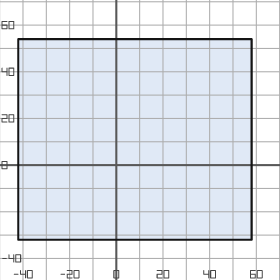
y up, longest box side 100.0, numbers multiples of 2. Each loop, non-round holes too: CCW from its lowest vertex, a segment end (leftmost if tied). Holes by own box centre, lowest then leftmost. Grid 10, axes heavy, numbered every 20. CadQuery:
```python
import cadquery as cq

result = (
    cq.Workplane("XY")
    .moveTo(-42.0, -32.0)
    .lineTo(58.0, -32.0)
    .lineTo(58.0, 54.0)
    .lineTo(-42.0, 54.0)
    .close()
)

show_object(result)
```